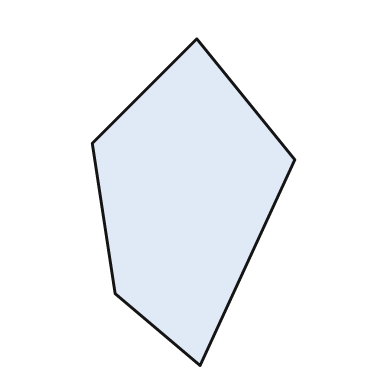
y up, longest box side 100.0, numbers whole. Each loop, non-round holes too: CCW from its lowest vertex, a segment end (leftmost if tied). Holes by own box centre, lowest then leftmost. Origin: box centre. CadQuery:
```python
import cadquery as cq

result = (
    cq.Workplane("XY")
    .moveTo(2.0, -50.0)
    .lineTo(31.0, 13.0)
    .lineTo(1.0, 50.0)
    .lineTo(-31.0, 18.0)
    .lineTo(-24.0, -28.0)
    .close()
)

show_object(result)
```